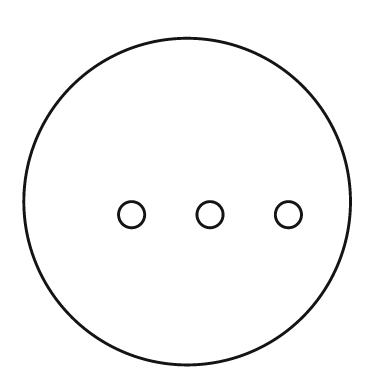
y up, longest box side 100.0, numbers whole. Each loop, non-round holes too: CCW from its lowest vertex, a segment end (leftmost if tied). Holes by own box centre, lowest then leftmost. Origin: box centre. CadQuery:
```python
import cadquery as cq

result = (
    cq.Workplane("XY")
    .moveTo(0.0, 0.0)
    .circle(50.0)
    .moveTo(-17.0, -4.0)
    .circle(4.0)
    .moveTo(7.0, -4.0)
    .circle(4.0)
    .moveTo(31.0, -4.0)
    .circle(4.0)
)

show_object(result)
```